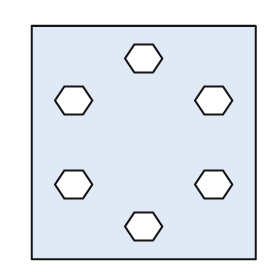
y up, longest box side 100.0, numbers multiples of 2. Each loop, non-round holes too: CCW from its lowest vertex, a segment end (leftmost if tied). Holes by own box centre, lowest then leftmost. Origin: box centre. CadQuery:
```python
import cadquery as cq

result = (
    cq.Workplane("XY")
    .moveTo(-48.0, -50.0)
    .lineTo(48.0, -50.0)
    .lineTo(48.0, 50.0)
    .lineTo(-48.0, 50.0)
    .close()
    .moveTo(-4.0, -42.0)
    .lineTo(4.0, -42.0)
    .lineTo(8.0, -36.0)
    .lineTo(4.0, -30.0)
    .lineTo(-4.0, -30.0)
    .lineTo(-8.0, -36.0)
    .close()
    .moveTo(-34.0, -24.0)
    .lineTo(-26.0, -24.0)
    .lineTo(-22.0, -18.0)
    .lineTo(-26.0, -12.0)
    .lineTo(-34.0, -12.0)
    .lineTo(-38.0, -18.0)
    .close()
    .moveTo(26.0, -24.0)
    .lineTo(34.0, -24.0)
    .lineTo(38.0, -18.0)
    .lineTo(34.0, -12.0)
    .lineTo(26.0, -12.0)
    .lineTo(22.0, -18.0)
    .close()
    .moveTo(-34.0, 12.0)
    .lineTo(-26.0, 12.0)
    .lineTo(-22.0, 18.0)
    .lineTo(-26.0, 24.0)
    .lineTo(-34.0, 24.0)
    .lineTo(-38.0, 18.0)
    .close()
    .moveTo(26.0, 12.0)
    .lineTo(34.0, 12.0)
    .lineTo(38.0, 18.0)
    .lineTo(34.0, 24.0)
    .lineTo(26.0, 24.0)
    .lineTo(22.0, 18.0)
    .close()
    .moveTo(-4.0, 30.0)
    .lineTo(4.0, 30.0)
    .lineTo(8.0, 36.0)
    .lineTo(4.0, 42.0)
    .lineTo(-4.0, 42.0)
    .lineTo(-8.0, 36.0)
    .close()
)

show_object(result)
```